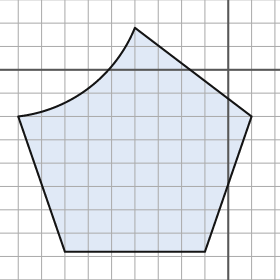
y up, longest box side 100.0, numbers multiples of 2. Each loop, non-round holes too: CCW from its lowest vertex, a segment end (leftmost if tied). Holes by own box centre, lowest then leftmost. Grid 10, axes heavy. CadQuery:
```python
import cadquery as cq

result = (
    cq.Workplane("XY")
    .moveTo(-70.0, -78.0)
    .lineTo(-10.0, -78.0)
    .lineTo(10.0, -20.0)
    .lineTo(-40.0, 18.0)
    .threePointArc((-60.0, -8.0), (-90.0, -20.0))
    .close()
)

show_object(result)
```